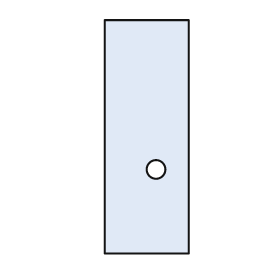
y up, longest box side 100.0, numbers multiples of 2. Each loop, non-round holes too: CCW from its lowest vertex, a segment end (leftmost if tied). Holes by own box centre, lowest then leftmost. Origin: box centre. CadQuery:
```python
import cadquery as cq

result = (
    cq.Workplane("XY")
    .moveTo(-18.0, -50.0)
    .lineTo(18.0, -50.0)
    .lineTo(18.0, 50.0)
    .lineTo(-18.0, 50.0)
    .close()
    .moveTo(4.0, -14.0)
    .circle(4.0)
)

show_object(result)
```